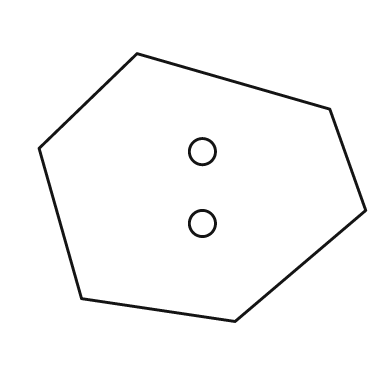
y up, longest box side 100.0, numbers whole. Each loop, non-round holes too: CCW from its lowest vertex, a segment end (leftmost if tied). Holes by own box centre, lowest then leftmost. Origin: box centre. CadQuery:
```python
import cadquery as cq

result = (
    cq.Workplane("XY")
    .moveTo(10.0, -41.0)
    .lineTo(50.0, -7.0)
    .lineTo(39.0, 24.0)
    .lineTo(-20.0, 41.0)
    .lineTo(-50.0, 12.0)
    .lineTo(-37.0, -34.0)
    .close()
    .moveTo(0.0, -11.0)
    .circle(4.0)
    .moveTo(0.0, 11.0)
    .circle(4.0)
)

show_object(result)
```